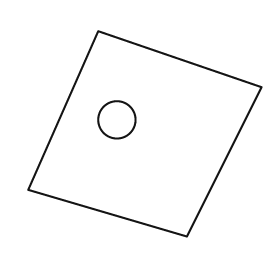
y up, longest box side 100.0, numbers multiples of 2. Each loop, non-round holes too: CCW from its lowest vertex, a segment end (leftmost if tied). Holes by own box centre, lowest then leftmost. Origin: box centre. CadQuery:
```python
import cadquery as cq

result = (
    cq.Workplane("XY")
    .moveTo(18.0, -44.0)
    .lineTo(50.0, 20.0)
    .lineTo(-20.0, 44.0)
    .lineTo(-50.0, -24.0)
    .close()
    .moveTo(-12.0, 6.0)
    .circle(8.0)
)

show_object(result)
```